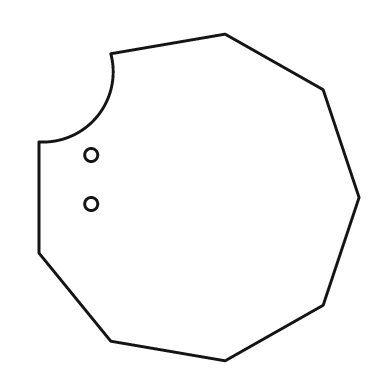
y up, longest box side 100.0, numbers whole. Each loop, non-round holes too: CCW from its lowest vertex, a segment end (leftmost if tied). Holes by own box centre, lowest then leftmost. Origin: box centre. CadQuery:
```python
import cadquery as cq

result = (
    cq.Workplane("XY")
    .moveTo(8.0, -50.0)
    .lineTo(38.0, -33.0)
    .lineTo(49.0, 0.0)
    .lineTo(38.0, 33.0)
    .lineTo(8.0, 50.0)
    .lineTo(-27.0, 44.0)
    .threePointArc((-31.0, 25.0), (-49.0, 17.0))
    .lineTo(-49.0, -17.0)
    .lineTo(-27.0, -44.0)
    .close()
    .moveTo(-33.0, -2.0)
    .circle(2.0)
    .moveTo(-33.0, 13.0)
    .circle(2.0)
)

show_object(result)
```